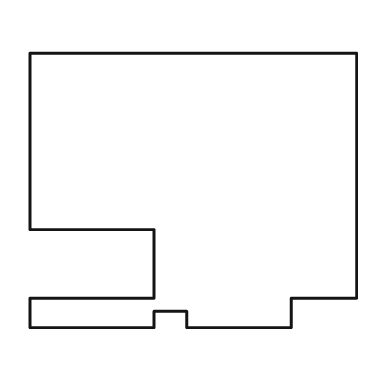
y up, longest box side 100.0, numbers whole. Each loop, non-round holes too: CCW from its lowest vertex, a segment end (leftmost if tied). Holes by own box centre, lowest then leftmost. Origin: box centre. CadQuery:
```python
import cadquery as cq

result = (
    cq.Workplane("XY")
    .moveTo(-50.0, -42.0)
    .lineTo(-12.0, -42.0)
    .lineTo(-12.0, -37.0)
    .lineTo(-2.0, -37.0)
    .lineTo(-2.0, -42.0)
    .lineTo(30.0, -42.0)
    .lineTo(30.0, -33.0)
    .lineTo(50.0, -33.0)
    .lineTo(50.0, 42.0)
    .lineTo(-50.0, 42.0)
    .lineTo(-50.0, -12.0)
    .lineTo(-12.0, -12.0)
    .lineTo(-12.0, -33.0)
    .lineTo(-50.0, -33.0)
    .close()
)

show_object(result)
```